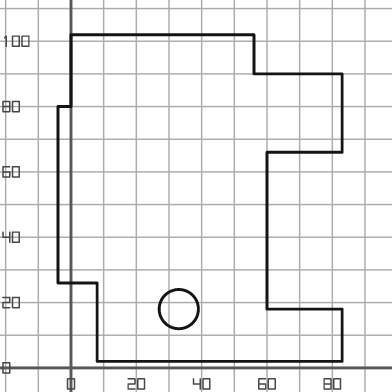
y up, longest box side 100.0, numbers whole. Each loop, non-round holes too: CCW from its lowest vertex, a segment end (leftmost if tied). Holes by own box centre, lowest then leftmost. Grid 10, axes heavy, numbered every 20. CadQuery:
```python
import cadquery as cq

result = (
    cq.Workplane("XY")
    .moveTo(8.0, 2.0)
    .lineTo(83.0, 2.0)
    .lineTo(83.0, 18.0)
    .lineTo(60.0, 18.0)
    .lineTo(60.0, 66.0)
    .lineTo(83.0, 66.0)
    .lineTo(83.0, 90.0)
    .lineTo(56.0, 90.0)
    .lineTo(56.0, 102.0)
    .lineTo(0.0, 102.0)
    .lineTo(0.0, 80.0)
    .lineTo(-4.0, 80.0)
    .lineTo(-4.0, 26.0)
    .lineTo(8.0, 26.0)
    .close()
    .moveTo(33.0, 18.0)
    .circle(6.0)
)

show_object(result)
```